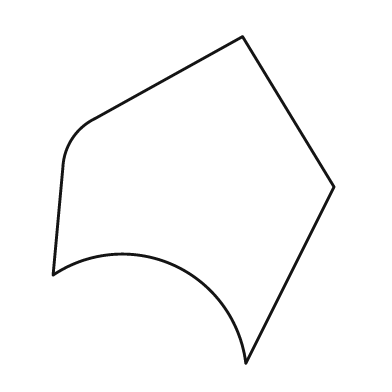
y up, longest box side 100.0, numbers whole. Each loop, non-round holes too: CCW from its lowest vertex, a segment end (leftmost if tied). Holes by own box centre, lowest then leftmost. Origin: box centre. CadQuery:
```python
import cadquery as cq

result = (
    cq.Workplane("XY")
    .moveTo(16.0, -50.0)
    .lineTo(43.0, 4.0)
    .lineTo(15.0, 50.0)
    .lineTo(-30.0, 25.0)
    .threePointArc((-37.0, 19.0), (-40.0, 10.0))
    .lineTo(-43.0, -23.0)
    .threePointArc((-6.0, -20.0), (16.0, -50.0))
    .close()
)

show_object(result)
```